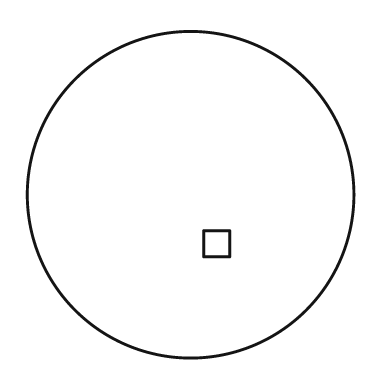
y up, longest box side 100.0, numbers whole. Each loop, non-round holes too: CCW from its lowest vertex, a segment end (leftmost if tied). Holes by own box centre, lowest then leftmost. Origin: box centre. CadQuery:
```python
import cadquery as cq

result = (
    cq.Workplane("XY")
    .moveTo(0.0, 0.0)
    .circle(50.0)
    .moveTo(4.0, -19.0)
    .lineTo(12.0, -19.0)
    .lineTo(12.0, -11.0)
    .lineTo(4.0, -11.0)
    .close()
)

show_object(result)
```